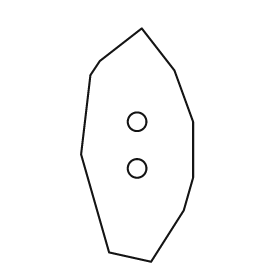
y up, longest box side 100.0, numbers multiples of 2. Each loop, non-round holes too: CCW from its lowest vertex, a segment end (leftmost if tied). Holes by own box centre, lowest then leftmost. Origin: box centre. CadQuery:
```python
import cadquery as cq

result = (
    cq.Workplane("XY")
    .moveTo(6.0, -50.0)
    .lineTo(20.0, -28.0)
    .lineTo(24.0, -14.0)
    .lineTo(24.0, 10.0)
    .lineTo(16.0, 32.0)
    .lineTo(2.0, 50.0)
    .lineTo(-16.0, 36.0)
    .lineTo(-20.0, 30.0)
    .lineTo(-24.0, -4.0)
    .lineTo(-12.0, -46.0)
    .close()
    .moveTo(0.0, -10.0)
    .circle(4.0)
    .moveTo(0.0, 10.0)
    .circle(4.0)
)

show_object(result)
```